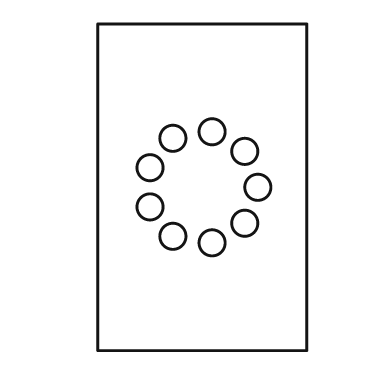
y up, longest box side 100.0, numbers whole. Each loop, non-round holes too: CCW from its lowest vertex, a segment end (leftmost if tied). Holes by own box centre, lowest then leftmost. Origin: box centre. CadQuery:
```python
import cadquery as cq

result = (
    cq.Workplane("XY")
    .moveTo(-32.0, -50.0)
    .lineTo(32.0, -50.0)
    .lineTo(32.0, 50.0)
    .lineTo(-32.0, 50.0)
    .close()
    .moveTo(3.0, -17.0)
    .circle(4.0)
    .moveTo(-9.0, -15.0)
    .circle(4.0)
    .moveTo(13.0, -11.0)
    .circle(4.0)
    .moveTo(-16.0, -6.0)
    .circle(4.0)
    .moveTo(17.0, 0.0)
    .circle(4.0)
    .moveTo(-16.0, 6.0)
    .circle(4.0)
    .moveTo(13.0, 11.0)
    .circle(4.0)
    .moveTo(-9.0, 15.0)
    .circle(4.0)
    .moveTo(3.0, 17.0)
    .circle(4.0)
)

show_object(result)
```